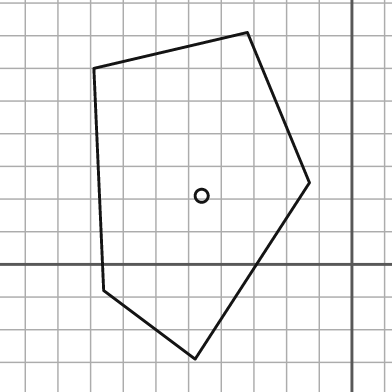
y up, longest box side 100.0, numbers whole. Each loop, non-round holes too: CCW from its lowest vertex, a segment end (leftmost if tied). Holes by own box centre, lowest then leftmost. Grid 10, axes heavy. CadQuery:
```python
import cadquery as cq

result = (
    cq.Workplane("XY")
    .moveTo(-48.0, -29.0)
    .lineTo(-13.0, 25.0)
    .lineTo(-32.0, 71.0)
    .lineTo(-79.0, 60.0)
    .lineTo(-76.0, -8.0)
    .close()
    .moveTo(-46.0, 21.0)
    .circle(2.0)
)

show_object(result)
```